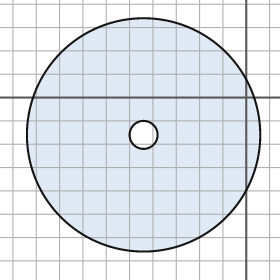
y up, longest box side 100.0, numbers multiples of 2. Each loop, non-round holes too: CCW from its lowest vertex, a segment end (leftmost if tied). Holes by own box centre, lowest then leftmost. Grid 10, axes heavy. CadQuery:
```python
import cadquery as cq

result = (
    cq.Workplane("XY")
    .moveTo(-44.0, -16.0)
    .circle(50.0)
    .moveTo(-44.0, -16.0)
    .circle(6.0)
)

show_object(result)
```